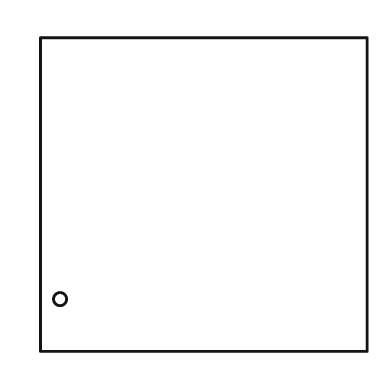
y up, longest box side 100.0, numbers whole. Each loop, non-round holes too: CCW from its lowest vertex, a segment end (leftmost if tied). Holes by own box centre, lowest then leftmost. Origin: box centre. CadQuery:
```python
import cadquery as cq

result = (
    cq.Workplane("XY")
    .moveTo(-50.0, -48.0)
    .lineTo(50.0, -48.0)
    .lineTo(50.0, 48.0)
    .lineTo(-50.0, 48.0)
    .close()
    .moveTo(-44.0, -32.0)
    .circle(2.0)
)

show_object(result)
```